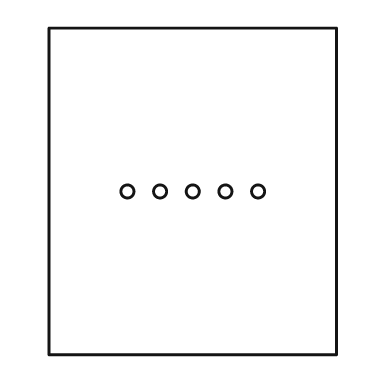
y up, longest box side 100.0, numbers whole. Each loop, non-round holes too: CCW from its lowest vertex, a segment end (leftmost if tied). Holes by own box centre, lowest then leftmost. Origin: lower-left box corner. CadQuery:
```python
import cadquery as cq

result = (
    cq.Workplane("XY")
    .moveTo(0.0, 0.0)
    .lineTo(88.0, 0.0)
    .lineTo(88.0, 100.0)
    .lineTo(0.0, 100.0)
    .close()
    .moveTo(24.0, 50.0)
    .circle(2.0)
    .moveTo(34.0, 50.0)
    .circle(2.0)
    .moveTo(44.0, 50.0)
    .circle(2.0)
    .moveTo(54.0, 50.0)
    .circle(2.0)
    .moveTo(64.0, 50.0)
    .circle(2.0)
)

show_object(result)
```